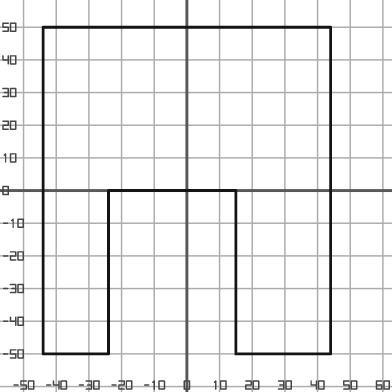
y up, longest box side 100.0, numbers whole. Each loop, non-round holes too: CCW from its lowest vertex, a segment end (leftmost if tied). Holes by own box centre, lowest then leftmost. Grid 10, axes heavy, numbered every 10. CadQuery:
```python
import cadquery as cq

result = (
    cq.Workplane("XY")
    .moveTo(-44.0, -50.0)
    .lineTo(-24.0, -50.0)
    .lineTo(-24.0, 0.0)
    .lineTo(15.0, 0.0)
    .lineTo(15.0, -50.0)
    .lineTo(44.0, -50.0)
    .lineTo(44.0, 50.0)
    .lineTo(-44.0, 50.0)
    .close()
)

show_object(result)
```